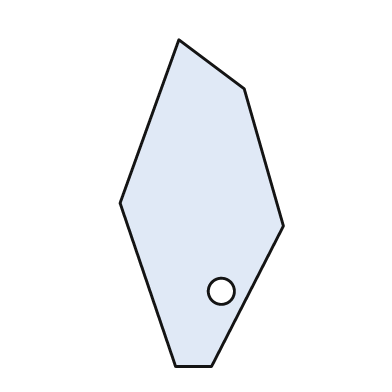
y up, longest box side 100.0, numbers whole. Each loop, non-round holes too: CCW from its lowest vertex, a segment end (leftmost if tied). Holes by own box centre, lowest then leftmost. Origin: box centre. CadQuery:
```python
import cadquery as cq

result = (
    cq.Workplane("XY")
    .moveTo(-8.0, -50.0)
    .lineTo(3.0, -50.0)
    .lineTo(25.0, -7.0)
    .lineTo(13.0, 35.0)
    .lineTo(-7.0, 50.0)
    .lineTo(-25.0, 0.0)
    .close()
    .moveTo(6.0, -27.0)
    .circle(4.0)
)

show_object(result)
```